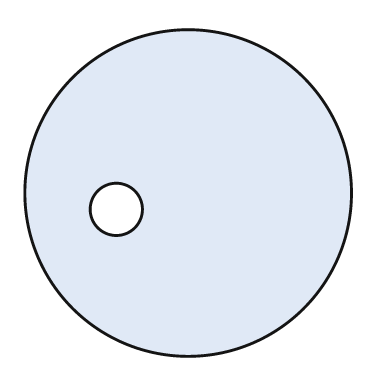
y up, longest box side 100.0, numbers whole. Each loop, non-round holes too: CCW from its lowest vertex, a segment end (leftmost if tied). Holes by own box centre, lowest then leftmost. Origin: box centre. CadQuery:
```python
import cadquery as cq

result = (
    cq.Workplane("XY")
    .moveTo(0.0, 0.0)
    .circle(50.0)
    .moveTo(-22.0, -5.0)
    .circle(8.0)
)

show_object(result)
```